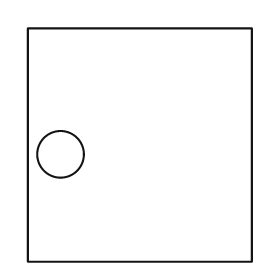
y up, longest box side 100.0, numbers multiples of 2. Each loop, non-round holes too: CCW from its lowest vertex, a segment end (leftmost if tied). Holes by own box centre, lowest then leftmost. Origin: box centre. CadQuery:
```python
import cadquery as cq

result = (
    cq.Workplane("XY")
    .moveTo(-48.0, -50.0)
    .lineTo(48.0, -50.0)
    .lineTo(48.0, 50.0)
    .lineTo(-48.0, 50.0)
    .close()
    .moveTo(-34.0, -4.0)
    .circle(10.0)
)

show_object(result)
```